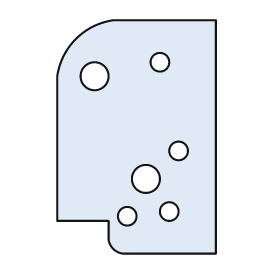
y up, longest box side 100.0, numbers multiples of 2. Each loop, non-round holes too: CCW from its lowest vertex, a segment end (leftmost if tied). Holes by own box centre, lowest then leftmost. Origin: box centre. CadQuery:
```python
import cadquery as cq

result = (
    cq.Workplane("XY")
    .moveTo(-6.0, -50.0)
    .lineTo(34.0, -50.0)
    .lineTo(34.0, 50.0)
    .lineTo(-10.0, 50.0)
    .threePointArc((-26.0, 42.0), (-34.0, 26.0))
    .lineTo(-34.0, -36.0)
    .lineTo(-12.0, -36.0)
    .lineTo(-12.0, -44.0)
    .threePointArc((-10.0, -48.0), (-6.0, -50.0))
    .close()
    .moveTo(-4.0, -34.0)
    .circle(4.0)
    .moveTo(14.0, -32.0)
    .circle(4.0)
    .moveTo(4.0, -18.0)
    .circle(6.0)
    .moveTo(18.0, -6.0)
    .circle(4.0)
    .moveTo(-18.0, 26.0)
    .circle(6.0)
    .moveTo(10.0, 32.0)
    .circle(4.0)
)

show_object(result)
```